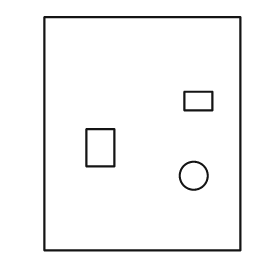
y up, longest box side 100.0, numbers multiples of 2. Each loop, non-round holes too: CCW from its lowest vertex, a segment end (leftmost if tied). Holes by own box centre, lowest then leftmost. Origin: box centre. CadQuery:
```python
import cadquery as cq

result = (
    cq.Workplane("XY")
    .moveTo(-42.0, -50.0)
    .lineTo(42.0, -50.0)
    .lineTo(42.0, 50.0)
    .lineTo(-42.0, 50.0)
    .close()
    .moveTo(22.0, -18.0)
    .circle(6.0)
    .moveTo(-24.0, -14.0)
    .lineTo(-12.0, -14.0)
    .lineTo(-12.0, 2.0)
    .lineTo(-24.0, 2.0)
    .close()
    .moveTo(18.0, 10.0)
    .lineTo(30.0, 10.0)
    .lineTo(30.0, 18.0)
    .lineTo(18.0, 18.0)
    .close()
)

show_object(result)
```